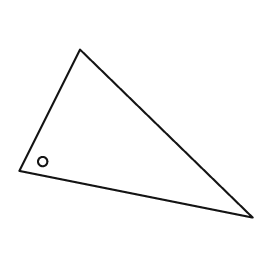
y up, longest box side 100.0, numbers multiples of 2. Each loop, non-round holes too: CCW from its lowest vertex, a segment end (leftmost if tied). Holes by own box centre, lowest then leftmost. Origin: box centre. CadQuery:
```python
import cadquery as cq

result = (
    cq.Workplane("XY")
    .moveTo(50.0, -36.0)
    .lineTo(-24.0, 36.0)
    .lineTo(-50.0, -16.0)
    .close()
    .moveTo(-40.0, -12.0)
    .circle(2.0)
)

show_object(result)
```